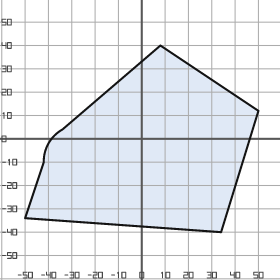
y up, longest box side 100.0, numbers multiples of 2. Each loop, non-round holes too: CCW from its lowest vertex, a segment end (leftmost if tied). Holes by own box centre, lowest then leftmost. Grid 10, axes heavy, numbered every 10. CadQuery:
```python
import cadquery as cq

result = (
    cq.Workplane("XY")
    .moveTo(34.0, -40.0)
    .lineTo(50.0, 12.0)
    .lineTo(8.0, 40.0)
    .lineTo(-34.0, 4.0)
    .threePointArc((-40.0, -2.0), (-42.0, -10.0))
    .lineTo(-50.0, -34.0)
    .close()
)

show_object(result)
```